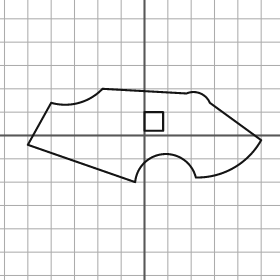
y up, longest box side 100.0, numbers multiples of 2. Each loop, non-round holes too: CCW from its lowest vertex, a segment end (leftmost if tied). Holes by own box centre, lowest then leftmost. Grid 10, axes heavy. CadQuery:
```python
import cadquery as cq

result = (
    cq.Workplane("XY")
    .moveTo(-4.0, -20.0)
    .threePointArc((8.0, -8.0), (22.0, -18.0))
    .threePointArc((38.0, -14.0), (50.0, -2.0))
    .lineTo(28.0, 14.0)
    .threePointArc((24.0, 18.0), (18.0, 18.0))
    .lineTo(-18.0, 20.0)
    .threePointArc((-28.0, 14.0), (-40.0, 14.0))
    .lineTo(-50.0, -4.0)
    .close()
    .moveTo(0.0, 2.0)
    .lineTo(8.0, 2.0)
    .lineTo(8.0, 10.0)
    .lineTo(0.0, 10.0)
    .close()
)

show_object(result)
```